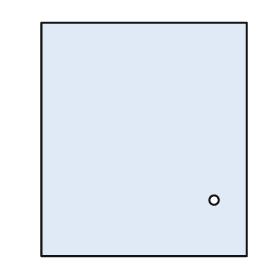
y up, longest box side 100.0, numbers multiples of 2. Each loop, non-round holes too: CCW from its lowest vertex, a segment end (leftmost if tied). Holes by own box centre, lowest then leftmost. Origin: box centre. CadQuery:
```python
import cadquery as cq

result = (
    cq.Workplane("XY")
    .moveTo(-44.0, -50.0)
    .lineTo(44.0, -50.0)
    .lineTo(44.0, 50.0)
    .lineTo(-44.0, 50.0)
    .close()
    .moveTo(30.0, -26.0)
    .circle(2.0)
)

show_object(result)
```